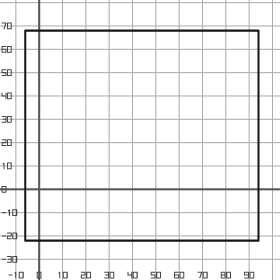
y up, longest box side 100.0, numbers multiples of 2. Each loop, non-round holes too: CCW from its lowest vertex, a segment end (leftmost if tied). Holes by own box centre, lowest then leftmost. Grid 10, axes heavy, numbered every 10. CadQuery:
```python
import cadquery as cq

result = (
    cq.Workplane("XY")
    .moveTo(-6.0, -22.0)
    .lineTo(94.0, -22.0)
    .lineTo(94.0, 68.0)
    .lineTo(-6.0, 68.0)
    .close()
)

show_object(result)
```